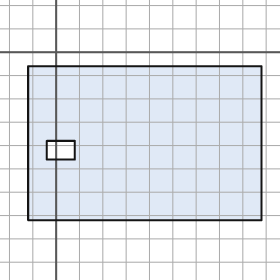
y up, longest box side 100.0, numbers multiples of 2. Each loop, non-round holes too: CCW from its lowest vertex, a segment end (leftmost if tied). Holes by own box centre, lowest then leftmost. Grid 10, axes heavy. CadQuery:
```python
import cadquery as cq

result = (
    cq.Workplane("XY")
    .moveTo(-12.0, -72.0)
    .lineTo(88.0, -72.0)
    .lineTo(88.0, -6.0)
    .lineTo(-12.0, -6.0)
    .close()
    .moveTo(-4.0, -46.0)
    .lineTo(8.0, -46.0)
    .lineTo(8.0, -38.0)
    .lineTo(-4.0, -38.0)
    .close()
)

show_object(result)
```